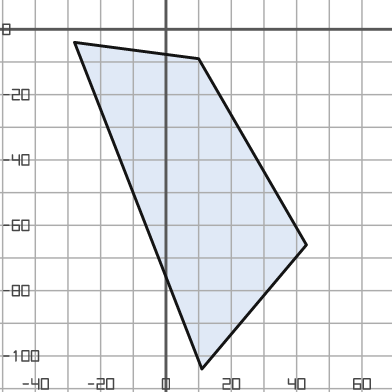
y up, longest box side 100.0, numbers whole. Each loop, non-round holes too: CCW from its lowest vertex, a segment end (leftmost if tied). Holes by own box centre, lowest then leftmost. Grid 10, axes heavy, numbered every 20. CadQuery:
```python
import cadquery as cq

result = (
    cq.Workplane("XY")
    .moveTo(11.0, -104.0)
    .lineTo(43.0, -66.0)
    .lineTo(10.0, -9.0)
    .lineTo(-28.0, -4.0)
    .close()
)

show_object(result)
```